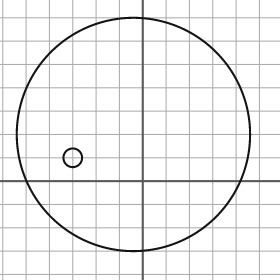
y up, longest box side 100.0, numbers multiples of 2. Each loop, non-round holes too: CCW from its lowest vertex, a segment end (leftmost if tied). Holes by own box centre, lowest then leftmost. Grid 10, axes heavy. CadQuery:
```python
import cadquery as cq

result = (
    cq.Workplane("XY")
    .moveTo(-4.0, 20.0)
    .circle(50.0)
    .moveTo(-30.0, 10.0)
    .circle(4.0)
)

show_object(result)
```